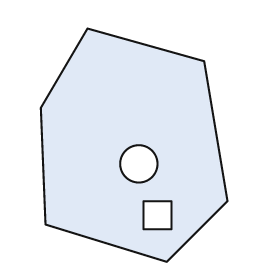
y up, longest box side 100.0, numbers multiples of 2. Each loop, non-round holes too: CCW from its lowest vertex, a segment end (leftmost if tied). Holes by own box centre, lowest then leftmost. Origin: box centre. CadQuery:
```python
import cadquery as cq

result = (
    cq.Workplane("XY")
    .moveTo(14.0, -50.0)
    .lineTo(40.0, -24.0)
    .lineTo(30.0, 36.0)
    .lineTo(-20.0, 50.0)
    .lineTo(-40.0, 16.0)
    .lineTo(-38.0, -34.0)
    .close()
    .moveTo(4.0, -36.0)
    .lineTo(16.0, -36.0)
    .lineTo(16.0, -24.0)
    .lineTo(4.0, -24.0)
    .close()
    .moveTo(2.0, -8.0)
    .circle(8.0)
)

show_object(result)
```